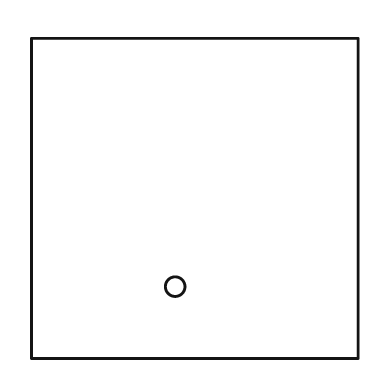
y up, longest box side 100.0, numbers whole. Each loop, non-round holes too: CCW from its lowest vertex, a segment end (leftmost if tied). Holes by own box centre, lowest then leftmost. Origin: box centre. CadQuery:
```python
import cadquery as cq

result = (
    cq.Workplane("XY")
    .moveTo(-50.0, -49.0)
    .lineTo(50.0, -49.0)
    .lineTo(50.0, 49.0)
    .lineTo(-50.0, 49.0)
    .close()
    .moveTo(-6.0, -27.0)
    .circle(3.0)
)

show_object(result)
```